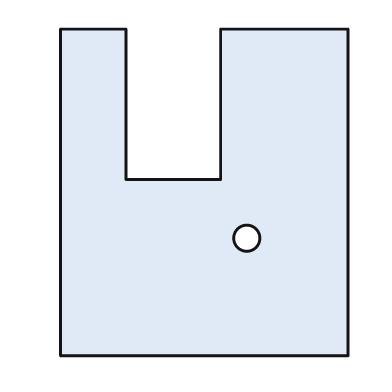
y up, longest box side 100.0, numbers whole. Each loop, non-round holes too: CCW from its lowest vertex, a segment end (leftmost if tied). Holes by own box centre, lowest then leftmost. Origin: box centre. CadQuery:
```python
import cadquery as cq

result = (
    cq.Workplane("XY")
    .moveTo(-44.0, -50.0)
    .lineTo(44.0, -50.0)
    .lineTo(44.0, 50.0)
    .lineTo(5.0, 50.0)
    .lineTo(5.0, 4.0)
    .lineTo(-24.0, 4.0)
    .lineTo(-24.0, 50.0)
    .lineTo(-44.0, 50.0)
    .close()
    .moveTo(13.0, -14.0)
    .circle(4.0)
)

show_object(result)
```